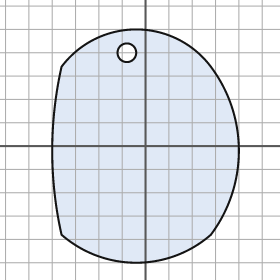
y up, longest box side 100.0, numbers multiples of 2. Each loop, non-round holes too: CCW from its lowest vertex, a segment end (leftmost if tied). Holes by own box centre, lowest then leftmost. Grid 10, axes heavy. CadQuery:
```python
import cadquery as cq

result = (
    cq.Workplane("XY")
    .moveTo(-36.0, -38.0)
    .threePointArc((-4.0, -50.0), (28.0, -38.0))
    .threePointArc((40.0, -2.0), (28.0, 34.0))
    .threePointArc((-4.0, 50.0), (-36.0, 34.0))
    .threePointArc((-40.0, -2.0), (-36.0, -38.0))
    .close()
    .moveTo(-8.0, 40.0)
    .circle(4.0)
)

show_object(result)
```